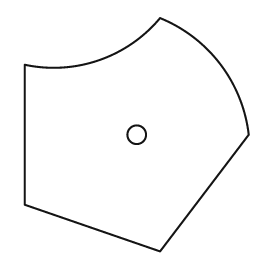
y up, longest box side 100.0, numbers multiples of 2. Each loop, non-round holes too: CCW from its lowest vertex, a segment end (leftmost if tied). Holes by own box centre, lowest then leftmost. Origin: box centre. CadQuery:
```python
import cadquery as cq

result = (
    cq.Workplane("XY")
    .moveTo(10.0, -50.0)
    .lineTo(48.0, 0.0)
    .threePointArc((36.0, 30.0), (10.0, 50.0))
    .threePointArc((-16.0, 32.0), (-48.0, 30.0))
    .lineTo(-48.0, -30.0)
    .close()
    .moveTo(0.0, 0.0)
    .circle(4.0)
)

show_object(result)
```